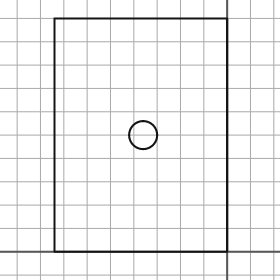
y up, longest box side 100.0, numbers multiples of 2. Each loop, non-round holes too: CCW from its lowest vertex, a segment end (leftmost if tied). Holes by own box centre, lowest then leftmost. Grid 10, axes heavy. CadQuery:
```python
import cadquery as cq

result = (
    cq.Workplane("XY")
    .moveTo(-74.0, 0.0)
    .lineTo(0.0, 0.0)
    .lineTo(0.0, 100.0)
    .lineTo(-74.0, 100.0)
    .close()
    .moveTo(-36.0, 50.0)
    .circle(6.0)
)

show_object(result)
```